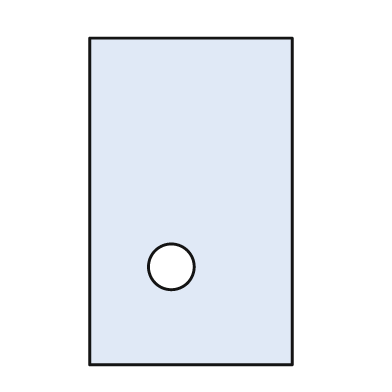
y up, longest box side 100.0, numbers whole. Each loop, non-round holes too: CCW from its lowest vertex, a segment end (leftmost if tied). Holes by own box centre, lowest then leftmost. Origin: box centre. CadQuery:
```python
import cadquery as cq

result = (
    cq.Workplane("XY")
    .moveTo(-31.0, -50.0)
    .lineTo(31.0, -50.0)
    .lineTo(31.0, 50.0)
    .lineTo(-31.0, 50.0)
    .close()
    .moveTo(-6.0, -20.0)
    .circle(7.0)
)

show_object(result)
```